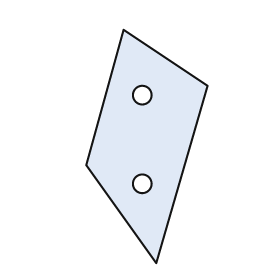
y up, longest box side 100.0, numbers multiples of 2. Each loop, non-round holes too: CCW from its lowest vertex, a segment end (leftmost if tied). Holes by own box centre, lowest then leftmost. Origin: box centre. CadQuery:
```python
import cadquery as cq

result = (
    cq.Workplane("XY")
    .moveTo(4.0, -50.0)
    .lineTo(26.0, 26.0)
    .lineTo(-10.0, 50.0)
    .lineTo(-26.0, -8.0)
    .close()
    .moveTo(-2.0, -16.0)
    .circle(4.0)
    .moveTo(-2.0, 22.0)
    .circle(4.0)
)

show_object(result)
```